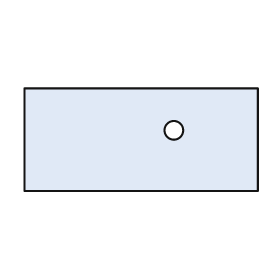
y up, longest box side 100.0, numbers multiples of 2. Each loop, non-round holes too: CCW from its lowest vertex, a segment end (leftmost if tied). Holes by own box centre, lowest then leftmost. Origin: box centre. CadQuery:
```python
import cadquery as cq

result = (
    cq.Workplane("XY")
    .moveTo(-50.0, -22.0)
    .lineTo(50.0, -22.0)
    .lineTo(50.0, 22.0)
    .lineTo(-50.0, 22.0)
    .close()
    .moveTo(14.0, 4.0)
    .circle(4.0)
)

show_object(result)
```